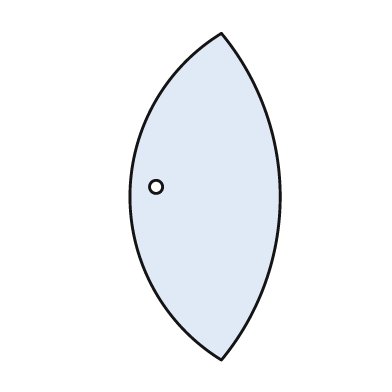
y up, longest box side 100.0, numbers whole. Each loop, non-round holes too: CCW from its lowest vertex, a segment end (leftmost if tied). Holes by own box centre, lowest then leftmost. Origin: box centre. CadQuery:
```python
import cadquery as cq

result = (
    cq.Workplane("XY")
    .moveTo(5.0, -50.0)
    .threePointArc((23.0, 0.0), (5.0, 50.0))
    .threePointArc((-23.0, 0.0), (5.0, -50.0))
    .close()
    .moveTo(-15.0, 3.0)
    .circle(2.0)
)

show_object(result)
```